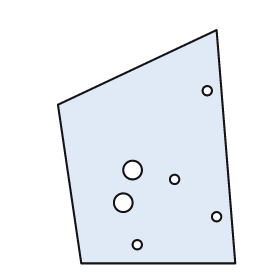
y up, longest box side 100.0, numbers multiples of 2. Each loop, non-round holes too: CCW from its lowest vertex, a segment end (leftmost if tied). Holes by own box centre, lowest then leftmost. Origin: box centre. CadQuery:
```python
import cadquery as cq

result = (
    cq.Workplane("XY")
    .moveTo(-28.0, -50.0)
    .lineTo(38.0, -50.0)
    .lineTo(30.0, 50.0)
    .lineTo(-38.0, 18.0)
    .close()
    .moveTo(-4.0, -42.0)
    .circle(2.0)
    .moveTo(30.0, -30.0)
    .circle(2.0)
    .moveTo(-10.0, -24.0)
    .circle(4.0)
    .moveTo(12.0, -14.0)
    .circle(2.0)
    .moveTo(-6.0, -10.0)
    .circle(4.0)
    .moveTo(26.0, 24.0)
    .circle(2.0)
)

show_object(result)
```